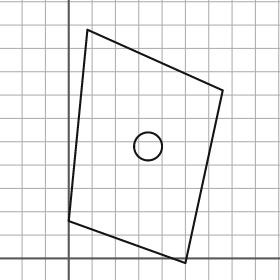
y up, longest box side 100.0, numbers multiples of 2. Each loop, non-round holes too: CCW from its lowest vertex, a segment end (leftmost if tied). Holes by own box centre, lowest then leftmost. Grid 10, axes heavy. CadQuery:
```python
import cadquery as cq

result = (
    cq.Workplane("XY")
    .moveTo(50.0, -2.0)
    .lineTo(66.0, 72.0)
    .lineTo(8.0, 98.0)
    .lineTo(0.0, 16.0)
    .close()
    .moveTo(34.0, 48.0)
    .circle(6.0)
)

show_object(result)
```